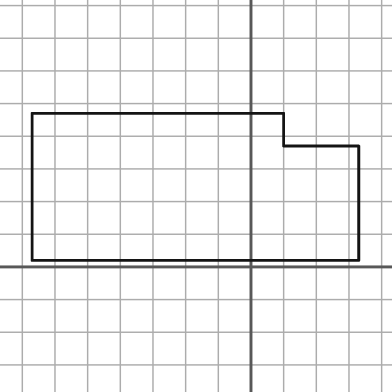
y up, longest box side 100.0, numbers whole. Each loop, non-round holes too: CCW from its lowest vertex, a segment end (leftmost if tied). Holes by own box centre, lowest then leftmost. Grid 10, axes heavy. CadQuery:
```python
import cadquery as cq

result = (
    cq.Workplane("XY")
    .moveTo(-67.0, 2.0)
    .lineTo(33.0, 2.0)
    .lineTo(33.0, 37.0)
    .lineTo(10.0, 37.0)
    .lineTo(10.0, 47.0)
    .lineTo(-67.0, 47.0)
    .close()
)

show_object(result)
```